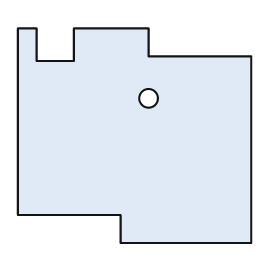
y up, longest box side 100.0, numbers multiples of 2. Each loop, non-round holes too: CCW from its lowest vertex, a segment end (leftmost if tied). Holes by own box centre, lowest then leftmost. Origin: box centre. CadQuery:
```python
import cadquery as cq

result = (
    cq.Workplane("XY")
    .moveTo(-6.0, -46.0)
    .lineTo(50.0, -46.0)
    .lineTo(50.0, 34.0)
    .lineTo(6.0, 34.0)
    .lineTo(6.0, 46.0)
    .lineTo(-26.0, 46.0)
    .lineTo(-26.0, 32.0)
    .lineTo(-42.0, 32.0)
    .lineTo(-42.0, 46.0)
    .lineTo(-50.0, 46.0)
    .lineTo(-50.0, -34.0)
    .lineTo(-6.0, -34.0)
    .close()
    .moveTo(6.0, 16.0)
    .circle(4.0)
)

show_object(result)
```